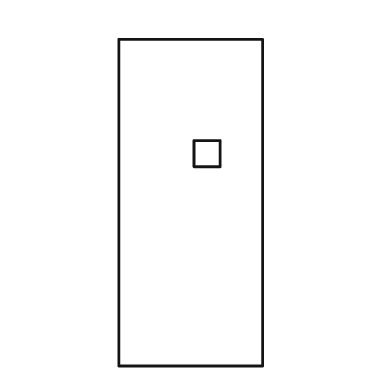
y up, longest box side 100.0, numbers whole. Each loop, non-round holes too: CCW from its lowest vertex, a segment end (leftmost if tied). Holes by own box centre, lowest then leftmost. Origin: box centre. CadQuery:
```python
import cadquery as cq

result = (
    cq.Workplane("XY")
    .moveTo(-22.0, -50.0)
    .lineTo(22.0, -50.0)
    .lineTo(22.0, 50.0)
    .lineTo(-22.0, 50.0)
    .close()
    .moveTo(1.0, 11.0)
    .lineTo(9.0, 11.0)
    .lineTo(9.0, 19.0)
    .lineTo(1.0, 19.0)
    .close()
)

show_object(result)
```